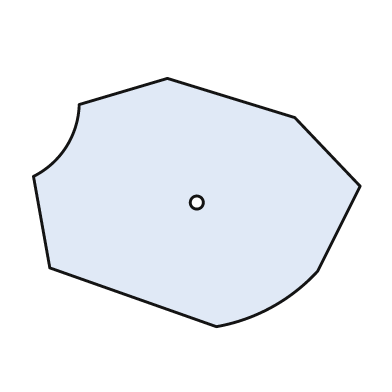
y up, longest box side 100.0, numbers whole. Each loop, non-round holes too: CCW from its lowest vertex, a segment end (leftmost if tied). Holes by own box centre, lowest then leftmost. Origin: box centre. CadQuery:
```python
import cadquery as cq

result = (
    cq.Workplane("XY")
    .moveTo(6.0, -38.0)
    .threePointArc((23.0, -32.0), (37.0, -21.0))
    .lineTo(50.0, 5.0)
    .lineTo(30.0, 26.0)
    .lineTo(-9.0, 38.0)
    .lineTo(-36.0, 30.0)
    .threePointArc((-40.0, 17.0), (-50.0, 8.0))
    .lineTo(-45.0, -20.0)
    .close()
    .moveTo(0.0, 0.0)
    .circle(2.0)
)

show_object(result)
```